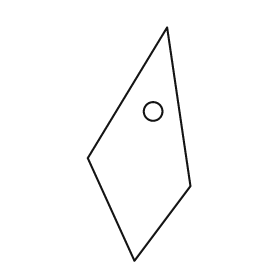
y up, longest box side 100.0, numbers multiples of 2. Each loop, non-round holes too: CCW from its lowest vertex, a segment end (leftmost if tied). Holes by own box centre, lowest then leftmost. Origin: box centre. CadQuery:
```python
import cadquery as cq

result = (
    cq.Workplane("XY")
    .moveTo(-2.0, -50.0)
    .lineTo(22.0, -18.0)
    .lineTo(12.0, 50.0)
    .lineTo(-22.0, -6.0)
    .close()
    .moveTo(6.0, 14.0)
    .circle(4.0)
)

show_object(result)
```